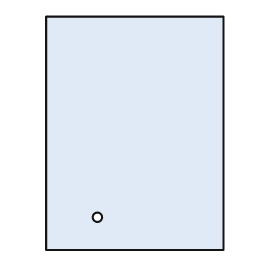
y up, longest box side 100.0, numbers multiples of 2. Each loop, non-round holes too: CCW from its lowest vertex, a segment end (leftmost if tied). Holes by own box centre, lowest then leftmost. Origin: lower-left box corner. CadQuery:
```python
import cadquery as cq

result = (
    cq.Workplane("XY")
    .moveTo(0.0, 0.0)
    .lineTo(76.0, 0.0)
    .lineTo(76.0, 100.0)
    .lineTo(0.0, 100.0)
    .close()
    .moveTo(22.0, 14.0)
    .circle(2.0)
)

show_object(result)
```